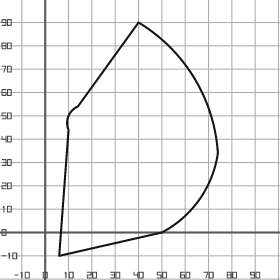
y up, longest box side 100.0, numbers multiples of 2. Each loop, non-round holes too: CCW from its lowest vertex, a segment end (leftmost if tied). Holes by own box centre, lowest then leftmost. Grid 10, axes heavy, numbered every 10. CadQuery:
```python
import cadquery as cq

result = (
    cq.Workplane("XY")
    .moveTo(6.0, -10.0)
    .lineTo(50.0, 0.0)
    .threePointArc((66.0, 14.0), (74.0, 34.0))
    .threePointArc((64.0, 66.0), (40.0, 90.0))
    .lineTo(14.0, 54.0)
    .threePointArc((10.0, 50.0), (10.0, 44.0))
    .close()
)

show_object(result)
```